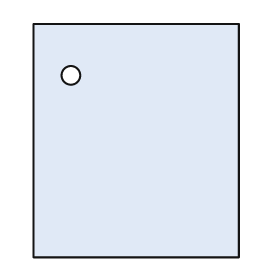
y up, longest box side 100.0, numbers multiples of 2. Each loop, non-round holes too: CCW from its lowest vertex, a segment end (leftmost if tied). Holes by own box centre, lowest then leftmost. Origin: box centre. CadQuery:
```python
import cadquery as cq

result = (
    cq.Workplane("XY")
    .moveTo(-44.0, -50.0)
    .lineTo(44.0, -50.0)
    .lineTo(44.0, 50.0)
    .lineTo(-44.0, 50.0)
    .close()
    .moveTo(-28.0, 28.0)
    .circle(4.0)
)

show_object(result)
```